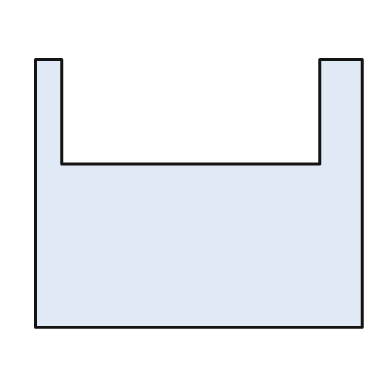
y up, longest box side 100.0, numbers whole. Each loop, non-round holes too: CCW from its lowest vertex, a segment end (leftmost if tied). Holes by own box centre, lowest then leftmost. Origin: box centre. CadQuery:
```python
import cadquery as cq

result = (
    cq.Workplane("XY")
    .moveTo(-50.0, -41.0)
    .lineTo(50.0, -41.0)
    .lineTo(50.0, 41.0)
    .lineTo(37.0, 41.0)
    .lineTo(37.0, 9.0)
    .lineTo(-42.0, 9.0)
    .lineTo(-42.0, 41.0)
    .lineTo(-50.0, 41.0)
    .close()
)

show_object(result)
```